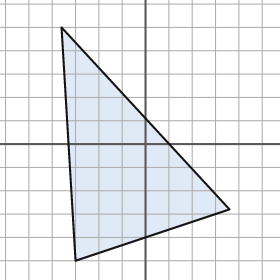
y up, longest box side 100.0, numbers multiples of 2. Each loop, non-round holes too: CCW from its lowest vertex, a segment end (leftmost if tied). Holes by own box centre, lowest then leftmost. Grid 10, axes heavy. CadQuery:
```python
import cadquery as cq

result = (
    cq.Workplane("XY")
    .moveTo(-30.0, -50.0)
    .lineTo(36.0, -28.0)
    .lineTo(-36.0, 50.0)
    .close()
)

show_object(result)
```